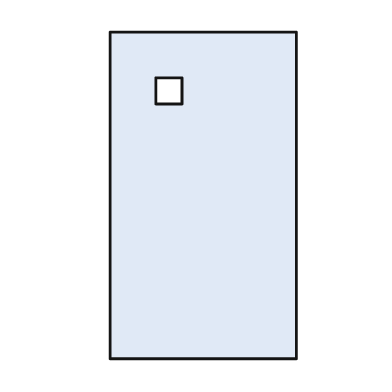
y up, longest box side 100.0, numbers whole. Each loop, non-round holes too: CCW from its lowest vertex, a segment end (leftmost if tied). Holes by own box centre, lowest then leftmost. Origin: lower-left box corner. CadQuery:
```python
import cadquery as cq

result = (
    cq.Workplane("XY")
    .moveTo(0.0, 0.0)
    .lineTo(57.0, 0.0)
    .lineTo(57.0, 100.0)
    .lineTo(0.0, 100.0)
    .close()
    .moveTo(14.0, 78.0)
    .lineTo(22.0, 78.0)
    .lineTo(22.0, 86.0)
    .lineTo(14.0, 86.0)
    .close()
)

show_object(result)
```